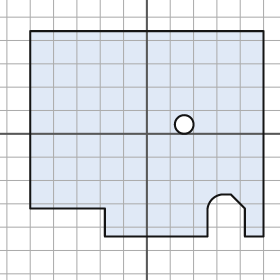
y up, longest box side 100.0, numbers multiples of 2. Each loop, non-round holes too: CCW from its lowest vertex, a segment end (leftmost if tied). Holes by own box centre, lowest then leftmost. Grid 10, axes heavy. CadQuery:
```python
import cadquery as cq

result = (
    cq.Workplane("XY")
    .moveTo(-18.0, -44.0)
    .lineTo(26.0, -44.0)
    .lineTo(26.0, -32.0)
    .threePointArc((28.0, -28.0), (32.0, -26.0))
    .lineTo(36.0, -26.0)
    .lineTo(42.0, -32.0)
    .lineTo(42.0, -44.0)
    .lineTo(50.0, -44.0)
    .lineTo(50.0, 44.0)
    .lineTo(-50.0, 44.0)
    .lineTo(-50.0, -32.0)
    .lineTo(-18.0, -32.0)
    .close()
    .moveTo(16.0, 4.0)
    .circle(4.0)
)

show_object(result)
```